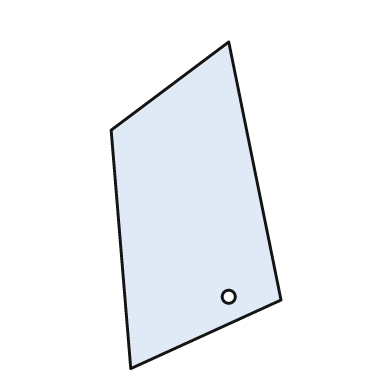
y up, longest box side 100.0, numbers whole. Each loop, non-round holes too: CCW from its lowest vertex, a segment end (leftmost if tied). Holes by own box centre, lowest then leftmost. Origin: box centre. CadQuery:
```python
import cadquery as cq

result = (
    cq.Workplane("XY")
    .moveTo(-20.0, -50.0)
    .lineTo(26.0, -29.0)
    .lineTo(10.0, 50.0)
    .lineTo(-26.0, 23.0)
    .close()
    .moveTo(10.0, -28.0)
    .circle(2.0)
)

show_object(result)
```